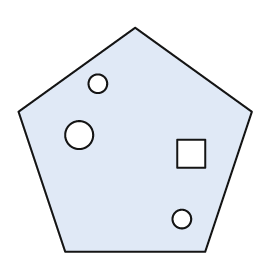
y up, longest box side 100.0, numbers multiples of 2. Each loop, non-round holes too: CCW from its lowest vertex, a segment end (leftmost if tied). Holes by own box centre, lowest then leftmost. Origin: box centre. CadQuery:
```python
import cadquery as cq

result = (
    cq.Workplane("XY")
    .moveTo(-30.0, -48.0)
    .lineTo(30.0, -48.0)
    .lineTo(50.0, 12.0)
    .lineTo(0.0, 48.0)
    .lineTo(-50.0, 12.0)
    .close()
    .moveTo(20.0, -34.0)
    .circle(4.0)
    .moveTo(18.0, -12.0)
    .lineTo(30.0, -12.0)
    .lineTo(30.0, 0.0)
    .lineTo(18.0, 0.0)
    .close()
    .moveTo(-24.0, 2.0)
    .circle(6.0)
    .moveTo(-16.0, 24.0)
    .circle(4.0)
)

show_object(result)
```